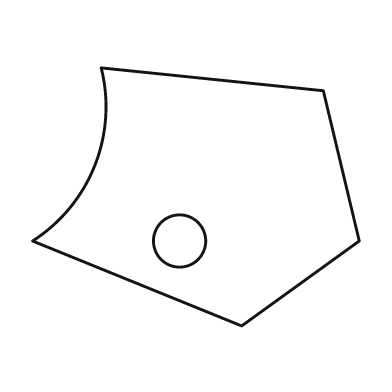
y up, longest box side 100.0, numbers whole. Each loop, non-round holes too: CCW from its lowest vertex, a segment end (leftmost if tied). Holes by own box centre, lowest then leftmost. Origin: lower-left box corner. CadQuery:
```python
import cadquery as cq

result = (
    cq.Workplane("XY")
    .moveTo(64.0, 0.0)
    .lineTo(100.0, 26.0)
    .lineTo(89.0, 72.0)
    .lineTo(21.0, 79.0)
    .threePointArc((19.0, 49.0), (0.0, 26.0))
    .close()
    .moveTo(45.0, 26.0)
    .circle(8.0)
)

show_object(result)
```